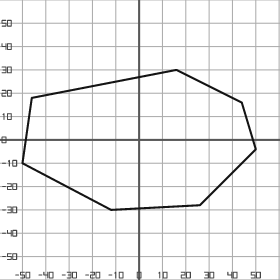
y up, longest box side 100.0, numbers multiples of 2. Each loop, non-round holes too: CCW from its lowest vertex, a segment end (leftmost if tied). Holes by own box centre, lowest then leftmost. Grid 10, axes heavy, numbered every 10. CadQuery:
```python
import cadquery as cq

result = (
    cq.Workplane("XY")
    .moveTo(-12.0, -30.0)
    .lineTo(26.0, -28.0)
    .lineTo(50.0, -4.0)
    .lineTo(44.0, 16.0)
    .lineTo(16.0, 30.0)
    .lineTo(-46.0, 18.0)
    .lineTo(-50.0, -10.0)
    .close()
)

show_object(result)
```